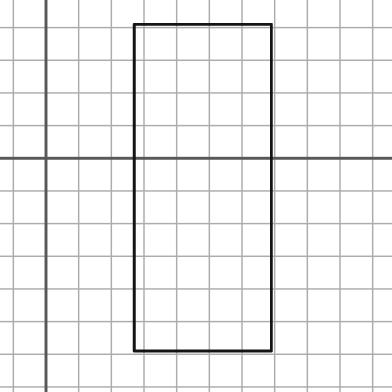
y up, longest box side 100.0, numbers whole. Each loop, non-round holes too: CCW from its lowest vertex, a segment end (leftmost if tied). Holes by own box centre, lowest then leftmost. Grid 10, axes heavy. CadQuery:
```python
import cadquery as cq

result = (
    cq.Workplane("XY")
    .moveTo(27.0, -59.0)
    .lineTo(69.0, -59.0)
    .lineTo(69.0, 41.0)
    .lineTo(27.0, 41.0)
    .close()
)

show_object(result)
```